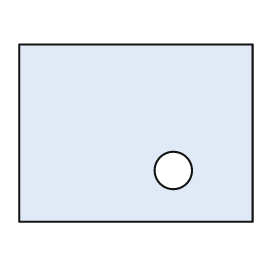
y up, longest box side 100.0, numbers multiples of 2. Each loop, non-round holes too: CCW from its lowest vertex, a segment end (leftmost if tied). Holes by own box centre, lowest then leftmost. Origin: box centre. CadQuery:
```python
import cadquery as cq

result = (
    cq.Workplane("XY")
    .moveTo(-50.0, -38.0)
    .lineTo(50.0, -38.0)
    .lineTo(50.0, 38.0)
    .lineTo(-50.0, 38.0)
    .close()
    .moveTo(16.0, -16.0)
    .circle(8.0)
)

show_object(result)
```